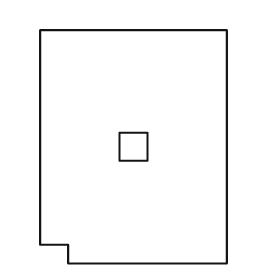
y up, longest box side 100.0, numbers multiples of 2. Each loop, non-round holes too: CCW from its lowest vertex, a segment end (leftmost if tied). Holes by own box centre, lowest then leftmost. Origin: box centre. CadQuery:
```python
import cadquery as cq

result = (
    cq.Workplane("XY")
    .moveTo(-28.0, -50.0)
    .lineTo(40.0, -50.0)
    .lineTo(40.0, 50.0)
    .lineTo(-40.0, 50.0)
    .lineTo(-40.0, -42.0)
    .lineTo(-28.0, -42.0)
    .close()
    .moveTo(-6.0, -6.0)
    .lineTo(6.0, -6.0)
    .lineTo(6.0, 6.0)
    .lineTo(-6.0, 6.0)
    .close()
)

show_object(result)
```